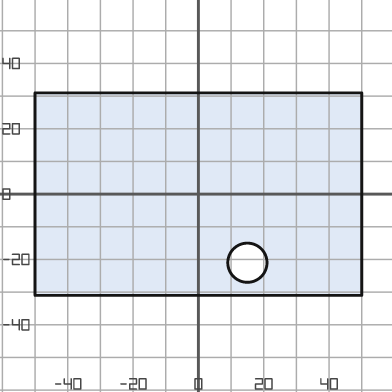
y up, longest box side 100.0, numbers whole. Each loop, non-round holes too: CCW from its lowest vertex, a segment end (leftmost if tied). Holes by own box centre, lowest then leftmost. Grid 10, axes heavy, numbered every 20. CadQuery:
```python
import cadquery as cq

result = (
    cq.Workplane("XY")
    .moveTo(-50.0, -31.0)
    .lineTo(50.0, -31.0)
    .lineTo(50.0, 31.0)
    .lineTo(-50.0, 31.0)
    .close()
    .moveTo(15.0, -21.0)
    .circle(6.0)
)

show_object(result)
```